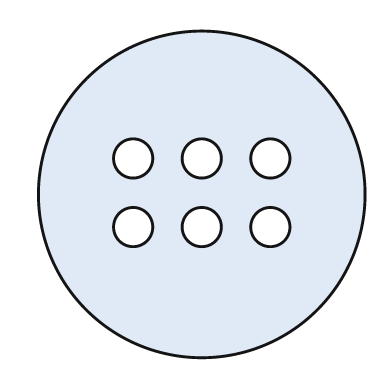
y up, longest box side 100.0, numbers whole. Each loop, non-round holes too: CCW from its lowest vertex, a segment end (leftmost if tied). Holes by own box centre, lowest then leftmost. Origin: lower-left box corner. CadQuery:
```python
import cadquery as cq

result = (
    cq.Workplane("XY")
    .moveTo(50.0, 50.0)
    .circle(50.0)
    .moveTo(29.0, 40.0)
    .circle(6.0)
    .moveTo(50.0, 40.0)
    .circle(6.0)
    .moveTo(71.0, 40.0)
    .circle(6.0)
    .moveTo(29.0, 61.0)
    .circle(6.0)
    .moveTo(50.0, 61.0)
    .circle(6.0)
    .moveTo(71.0, 61.0)
    .circle(6.0)
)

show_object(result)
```